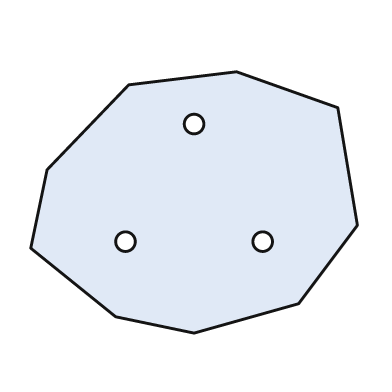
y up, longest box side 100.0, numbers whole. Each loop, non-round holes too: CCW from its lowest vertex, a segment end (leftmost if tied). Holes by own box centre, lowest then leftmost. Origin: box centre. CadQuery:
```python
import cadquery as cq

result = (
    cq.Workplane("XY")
    .moveTo(0.0, -40.0)
    .lineTo(32.0, -31.0)
    .lineTo(50.0, -7.0)
    .lineTo(44.0, 29.0)
    .lineTo(13.0, 40.0)
    .lineTo(-20.0, 36.0)
    .lineTo(-45.0, 10.0)
    .lineTo(-50.0, -14.0)
    .lineTo(-24.0, -35.0)
    .close()
    .moveTo(-21.0, -12.0)
    .circle(3.0)
    .moveTo(21.0, -12.0)
    .circle(3.0)
    .moveTo(0.0, 24.0)
    .circle(3.0)
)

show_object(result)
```